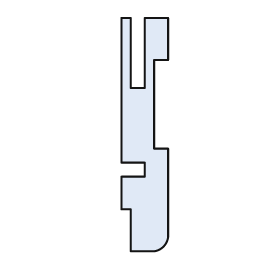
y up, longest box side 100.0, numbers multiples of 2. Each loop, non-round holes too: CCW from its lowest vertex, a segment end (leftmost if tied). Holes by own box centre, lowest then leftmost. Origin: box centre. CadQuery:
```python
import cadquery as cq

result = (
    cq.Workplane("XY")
    .moveTo(-6.0, -50.0)
    .lineTo(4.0, -50.0)
    .threePointArc((8.0, -48.0), (10.0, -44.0))
    .lineTo(10.0, -6.0)
    .lineTo(4.0, -6.0)
    .lineTo(4.0, 32.0)
    .lineTo(10.0, 32.0)
    .lineTo(10.0, 50.0)
    .lineTo(0.0, 50.0)
    .lineTo(0.0, 20.0)
    .lineTo(-6.0, 20.0)
    .lineTo(-6.0, 50.0)
    .lineTo(-10.0, 50.0)
    .lineTo(-10.0, -12.0)
    .lineTo(0.0, -12.0)
    .lineTo(0.0, -18.0)
    .lineTo(-10.0, -18.0)
    .lineTo(-10.0, -32.0)
    .lineTo(-6.0, -32.0)
    .close()
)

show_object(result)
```